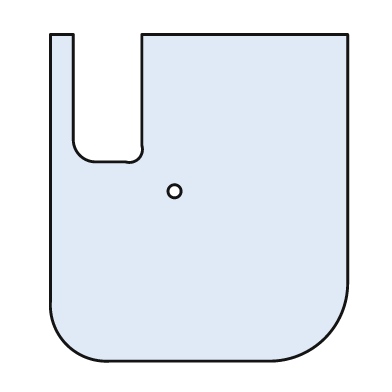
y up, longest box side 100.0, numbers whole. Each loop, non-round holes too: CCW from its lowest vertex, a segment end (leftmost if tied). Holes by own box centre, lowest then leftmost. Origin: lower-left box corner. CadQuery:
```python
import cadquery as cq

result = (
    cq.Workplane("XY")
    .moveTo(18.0, 0.0)
    .lineTo(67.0, 0.0)
    .threePointArc((84.0, 7.0), (91.0, 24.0))
    .lineTo(91.0, 100.0)
    .lineTo(28.0, 100.0)
    .lineTo(28.0, 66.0)
    .threePointArc((27.0, 62.0), (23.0, 61.0))
    .lineTo(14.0, 61.0)
    .threePointArc((9.0, 63.0), (7.0, 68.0))
    .lineTo(7.0, 100.0)
    .lineTo(0.0, 100.0)
    .lineTo(0.0, 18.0)
    .threePointArc((5.0, 5.0), (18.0, 0.0))
    .close()
    .moveTo(38.0, 52.0)
    .circle(2.0)
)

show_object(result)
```